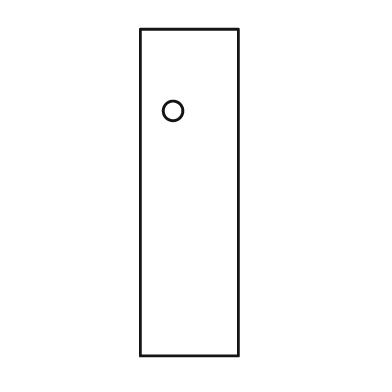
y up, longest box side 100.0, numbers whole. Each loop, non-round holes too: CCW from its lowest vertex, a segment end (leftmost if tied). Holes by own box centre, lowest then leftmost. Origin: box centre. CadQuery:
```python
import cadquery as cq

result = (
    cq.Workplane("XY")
    .moveTo(-15.0, -50.0)
    .lineTo(15.0, -50.0)
    .lineTo(15.0, 50.0)
    .lineTo(-15.0, 50.0)
    .close()
    .moveTo(-5.0, 25.0)
    .circle(3.0)
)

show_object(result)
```